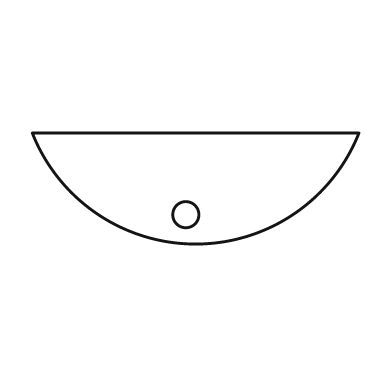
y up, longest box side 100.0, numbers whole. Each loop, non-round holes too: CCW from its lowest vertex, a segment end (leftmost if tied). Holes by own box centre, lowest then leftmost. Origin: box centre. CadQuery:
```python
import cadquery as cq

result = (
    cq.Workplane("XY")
    .moveTo(-50.0, 17.0)
    .threePointArc((0.0, -17.0), (50.0, 17.0))
    .close()
    .moveTo(-3.0, -8.0)
    .circle(4.0)
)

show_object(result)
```